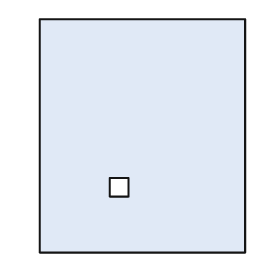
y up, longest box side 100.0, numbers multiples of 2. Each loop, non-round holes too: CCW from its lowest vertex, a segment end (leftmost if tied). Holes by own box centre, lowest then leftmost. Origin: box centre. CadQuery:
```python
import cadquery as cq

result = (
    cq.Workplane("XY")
    .moveTo(-44.0, -50.0)
    .lineTo(44.0, -50.0)
    .lineTo(44.0, 50.0)
    .lineTo(-44.0, 50.0)
    .close()
    .moveTo(-14.0, -26.0)
    .lineTo(-6.0, -26.0)
    .lineTo(-6.0, -18.0)
    .lineTo(-14.0, -18.0)
    .close()
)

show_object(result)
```